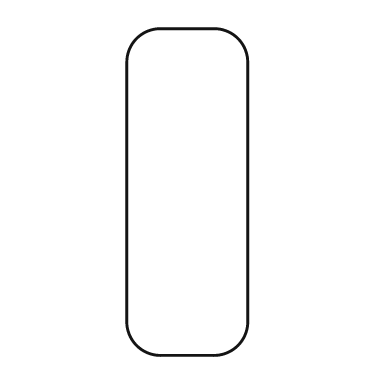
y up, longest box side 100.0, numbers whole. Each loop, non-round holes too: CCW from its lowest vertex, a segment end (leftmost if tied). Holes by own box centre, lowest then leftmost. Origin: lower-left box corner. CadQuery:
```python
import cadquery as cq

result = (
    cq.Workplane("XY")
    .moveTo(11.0, 0.0)
    .lineTo(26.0, 0.0)
    .threePointArc((34.0, 3.0), (37.0, 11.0))
    .lineTo(37.0, 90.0)
    .threePointArc((34.0, 97.0), (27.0, 100.0))
    .lineTo(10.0, 100.0)
    .threePointArc((3.0, 97.0), (0.0, 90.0))
    .lineTo(0.0, 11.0)
    .threePointArc((3.0, 3.0), (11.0, 0.0))
    .close()
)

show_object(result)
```